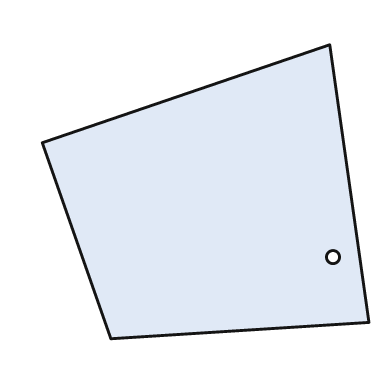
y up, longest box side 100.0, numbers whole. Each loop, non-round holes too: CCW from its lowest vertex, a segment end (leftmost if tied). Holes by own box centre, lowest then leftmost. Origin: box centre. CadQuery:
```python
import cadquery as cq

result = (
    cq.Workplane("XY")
    .moveTo(-29.0, -45.0)
    .lineTo(50.0, -40.0)
    .lineTo(38.0, 45.0)
    .lineTo(-50.0, 15.0)
    .close()
    .moveTo(39.0, -20.0)
    .circle(2.0)
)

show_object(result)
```